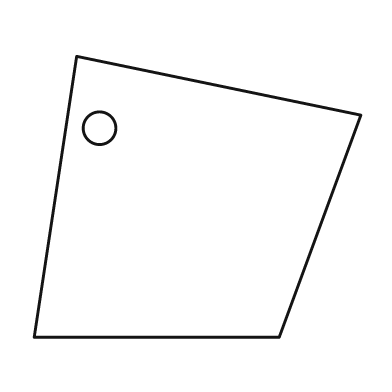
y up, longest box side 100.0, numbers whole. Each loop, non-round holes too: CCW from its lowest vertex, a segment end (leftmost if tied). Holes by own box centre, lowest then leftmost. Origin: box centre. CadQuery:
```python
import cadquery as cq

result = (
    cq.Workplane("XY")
    .moveTo(-50.0, -43.0)
    .lineTo(25.0, -43.0)
    .lineTo(50.0, 25.0)
    .lineTo(-37.0, 43.0)
    .close()
    .moveTo(-30.0, 21.0)
    .circle(5.0)
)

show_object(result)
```